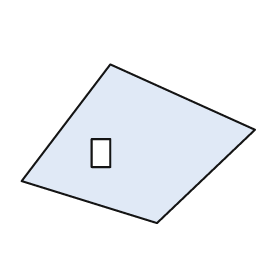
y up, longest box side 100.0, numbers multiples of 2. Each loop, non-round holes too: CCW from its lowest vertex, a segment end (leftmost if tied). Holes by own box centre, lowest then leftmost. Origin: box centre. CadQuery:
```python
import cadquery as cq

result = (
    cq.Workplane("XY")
    .moveTo(8.0, -34.0)
    .lineTo(50.0, 6.0)
    .lineTo(-12.0, 34.0)
    .lineTo(-50.0, -16.0)
    .close()
    .moveTo(-20.0, -10.0)
    .lineTo(-12.0, -10.0)
    .lineTo(-12.0, 2.0)
    .lineTo(-20.0, 2.0)
    .close()
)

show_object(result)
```